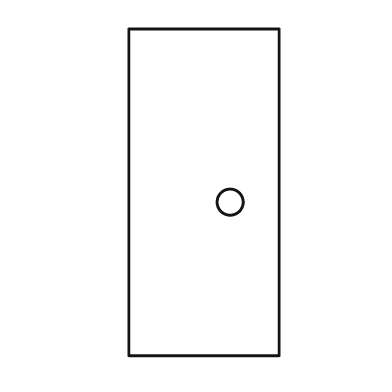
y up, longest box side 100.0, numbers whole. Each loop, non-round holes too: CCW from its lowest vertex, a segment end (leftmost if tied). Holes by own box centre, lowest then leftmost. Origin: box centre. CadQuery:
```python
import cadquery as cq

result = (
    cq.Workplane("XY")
    .moveTo(-23.0, -50.0)
    .lineTo(23.0, -50.0)
    .lineTo(23.0, 50.0)
    .lineTo(-23.0, 50.0)
    .close()
    .moveTo(8.0, -3.0)
    .circle(4.0)
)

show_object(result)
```